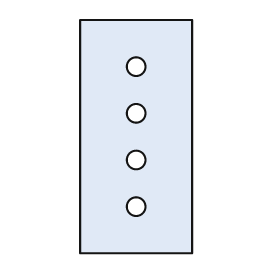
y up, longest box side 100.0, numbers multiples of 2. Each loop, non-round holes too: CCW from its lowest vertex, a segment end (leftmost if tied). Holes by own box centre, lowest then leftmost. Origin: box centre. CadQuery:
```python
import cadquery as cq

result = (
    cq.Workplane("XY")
    .moveTo(-24.0, -50.0)
    .lineTo(24.0, -50.0)
    .lineTo(24.0, 50.0)
    .lineTo(-24.0, 50.0)
    .close()
    .moveTo(0.0, -30.0)
    .circle(4.0)
    .moveTo(0.0, -10.0)
    .circle(4.0)
    .moveTo(0.0, 10.0)
    .circle(4.0)
    .moveTo(0.0, 30.0)
    .circle(4.0)
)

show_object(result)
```